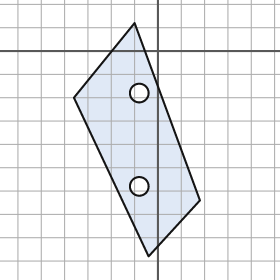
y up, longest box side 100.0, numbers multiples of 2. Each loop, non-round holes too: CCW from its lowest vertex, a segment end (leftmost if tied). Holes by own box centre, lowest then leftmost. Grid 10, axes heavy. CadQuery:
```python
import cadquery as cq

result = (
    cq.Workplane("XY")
    .moveTo(-4.0, -88.0)
    .lineTo(18.0, -64.0)
    .lineTo(-10.0, 12.0)
    .lineTo(-36.0, -20.0)
    .close()
    .moveTo(-8.0, -58.0)
    .circle(4.0)
    .moveTo(-8.0, -18.0)
    .circle(4.0)
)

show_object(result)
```